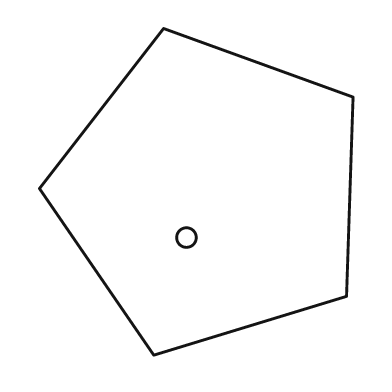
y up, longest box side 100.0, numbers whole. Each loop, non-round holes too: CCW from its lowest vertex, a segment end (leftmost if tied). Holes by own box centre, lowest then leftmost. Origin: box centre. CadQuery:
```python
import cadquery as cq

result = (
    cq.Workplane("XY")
    .moveTo(-13.0, -50.0)
    .lineTo(46.0, -32.0)
    .lineTo(48.0, 29.0)
    .lineTo(-10.0, 50.0)
    .lineTo(-48.0, 1.0)
    .close()
    .moveTo(-3.0, -14.0)
    .circle(3.0)
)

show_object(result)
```